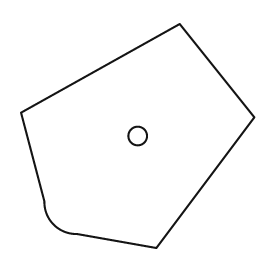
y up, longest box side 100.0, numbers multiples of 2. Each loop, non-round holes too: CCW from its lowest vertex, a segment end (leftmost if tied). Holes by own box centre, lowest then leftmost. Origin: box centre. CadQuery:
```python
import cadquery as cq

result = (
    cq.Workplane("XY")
    .moveTo(8.0, -48.0)
    .lineTo(50.0, 8.0)
    .lineTo(18.0, 48.0)
    .lineTo(-50.0, 10.0)
    .lineTo(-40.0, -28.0)
    .threePointArc((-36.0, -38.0), (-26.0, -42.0))
    .close()
    .moveTo(0.0, 0.0)
    .circle(4.0)
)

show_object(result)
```